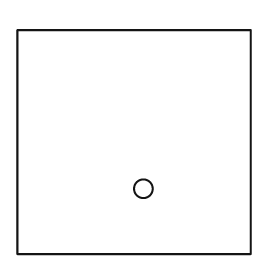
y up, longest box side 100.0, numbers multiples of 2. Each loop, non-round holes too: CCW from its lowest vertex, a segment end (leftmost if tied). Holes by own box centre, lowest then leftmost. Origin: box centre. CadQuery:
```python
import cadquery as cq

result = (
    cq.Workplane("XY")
    .moveTo(-50.0, -48.0)
    .lineTo(50.0, -48.0)
    .lineTo(50.0, 48.0)
    .lineTo(-50.0, 48.0)
    .close()
    .moveTo(4.0, -20.0)
    .circle(4.0)
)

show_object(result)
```